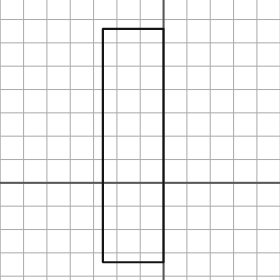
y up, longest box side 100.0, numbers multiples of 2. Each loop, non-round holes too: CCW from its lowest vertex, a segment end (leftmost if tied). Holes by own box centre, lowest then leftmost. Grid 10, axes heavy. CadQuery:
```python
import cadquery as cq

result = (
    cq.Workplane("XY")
    .moveTo(-26.0, -34.0)
    .lineTo(0.0, -34.0)
    .lineTo(0.0, 66.0)
    .lineTo(-26.0, 66.0)
    .close()
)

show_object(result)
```